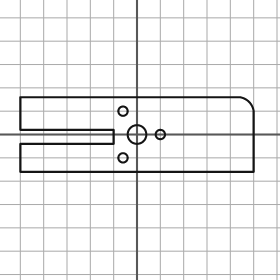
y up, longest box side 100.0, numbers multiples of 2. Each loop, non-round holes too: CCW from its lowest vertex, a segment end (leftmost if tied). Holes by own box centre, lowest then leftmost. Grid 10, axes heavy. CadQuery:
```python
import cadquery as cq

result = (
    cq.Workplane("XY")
    .moveTo(-50.0, -16.0)
    .lineTo(50.0, -16.0)
    .lineTo(50.0, 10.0)
    .threePointArc((48.0, 14.0), (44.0, 16.0))
    .lineTo(-50.0, 16.0)
    .lineTo(-50.0, 2.0)
    .lineTo(-10.0, 2.0)
    .lineTo(-10.0, -4.0)
    .lineTo(-50.0, -4.0)
    .close()
    .moveTo(-6.0, -10.0)
    .circle(2.0)
    .moveTo(0.0, 0.0)
    .circle(4.0)
    .moveTo(10.0, 0.0)
    .circle(2.0)
    .moveTo(-6.0, 10.0)
    .circle(2.0)
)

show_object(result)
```